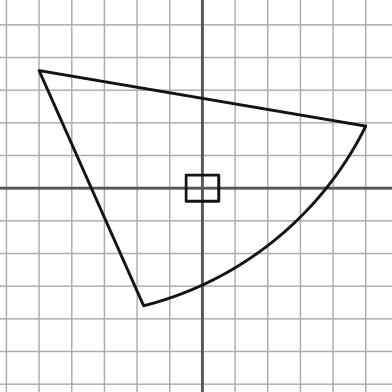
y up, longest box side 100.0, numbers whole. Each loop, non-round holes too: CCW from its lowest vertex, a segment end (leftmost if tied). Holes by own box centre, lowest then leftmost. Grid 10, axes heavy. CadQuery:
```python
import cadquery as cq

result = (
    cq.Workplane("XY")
    .moveTo(-18.0, -36.0)
    .threePointArc((22.0, -16.0), (50.0, 19.0))
    .lineTo(-50.0, 36.0)
    .close()
    .moveTo(-5.0, -4.0)
    .lineTo(5.0, -4.0)
    .lineTo(5.0, 4.0)
    .lineTo(-5.0, 4.0)
    .close()
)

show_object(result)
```